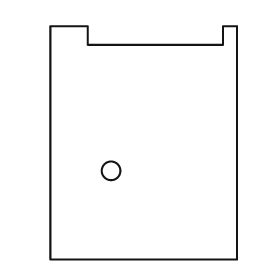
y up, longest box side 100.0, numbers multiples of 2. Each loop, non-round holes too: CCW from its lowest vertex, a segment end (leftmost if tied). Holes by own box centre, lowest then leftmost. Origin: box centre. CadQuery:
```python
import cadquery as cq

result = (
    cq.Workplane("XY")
    .moveTo(-40.0, -50.0)
    .lineTo(40.0, -50.0)
    .lineTo(40.0, 50.0)
    .lineTo(34.0, 50.0)
    .lineTo(34.0, 42.0)
    .lineTo(-24.0, 42.0)
    .lineTo(-24.0, 50.0)
    .lineTo(-40.0, 50.0)
    .close()
    .moveTo(-14.0, -12.0)
    .circle(4.0)
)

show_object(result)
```